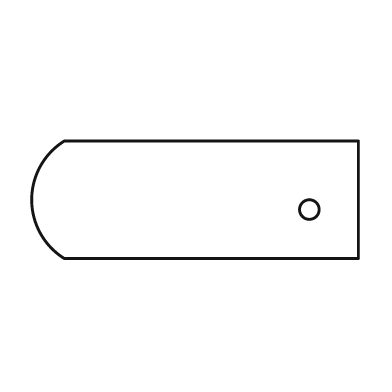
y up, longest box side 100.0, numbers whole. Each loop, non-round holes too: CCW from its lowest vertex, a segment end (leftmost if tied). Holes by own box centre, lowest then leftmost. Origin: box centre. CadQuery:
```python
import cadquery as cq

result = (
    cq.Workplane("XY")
    .moveTo(-40.0, -18.0)
    .lineTo(50.0, -18.0)
    .lineTo(50.0, 18.0)
    .lineTo(-40.0, 18.0)
    .threePointArc((-50.0, 0.0), (-40.0, -18.0))
    .close()
    .moveTo(35.0, -3.0)
    .circle(3.0)
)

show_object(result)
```